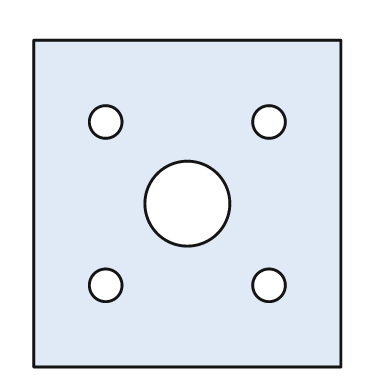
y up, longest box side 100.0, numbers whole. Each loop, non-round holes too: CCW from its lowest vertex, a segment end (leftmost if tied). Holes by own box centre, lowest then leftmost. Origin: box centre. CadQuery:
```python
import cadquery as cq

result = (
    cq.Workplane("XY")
    .moveTo(-47.0, -50.0)
    .lineTo(47.0, -50.0)
    .lineTo(47.0, 50.0)
    .lineTo(-47.0, 50.0)
    .close()
    .moveTo(-25.0, -25.0)
    .circle(5.0)
    .moveTo(25.0, -25.0)
    .circle(5.0)
    .moveTo(0.0, 0.0)
    .circle(13.0)
    .moveTo(-25.0, 25.0)
    .circle(5.0)
    .moveTo(25.0, 25.0)
    .circle(5.0)
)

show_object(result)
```